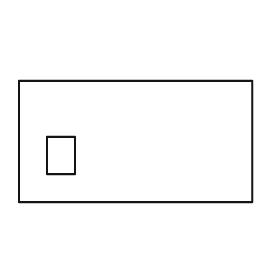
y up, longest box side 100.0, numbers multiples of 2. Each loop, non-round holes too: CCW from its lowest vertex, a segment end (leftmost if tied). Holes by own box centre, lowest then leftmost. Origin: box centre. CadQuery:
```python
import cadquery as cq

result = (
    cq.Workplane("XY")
    .moveTo(-50.0, -26.0)
    .lineTo(50.0, -26.0)
    .lineTo(50.0, 26.0)
    .lineTo(-50.0, 26.0)
    .close()
    .moveTo(-38.0, -14.0)
    .lineTo(-26.0, -14.0)
    .lineTo(-26.0, 2.0)
    .lineTo(-38.0, 2.0)
    .close()
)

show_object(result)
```